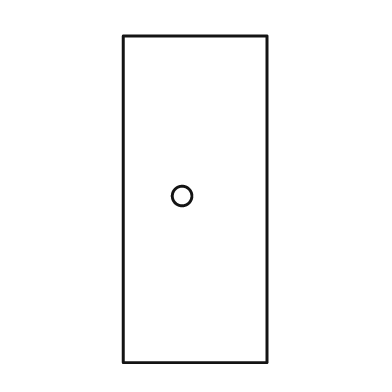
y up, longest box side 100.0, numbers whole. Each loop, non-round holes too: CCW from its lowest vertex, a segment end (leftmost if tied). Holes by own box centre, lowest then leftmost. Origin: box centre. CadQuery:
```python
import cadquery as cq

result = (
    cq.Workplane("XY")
    .moveTo(-22.0, -50.0)
    .lineTo(22.0, -50.0)
    .lineTo(22.0, 50.0)
    .lineTo(-22.0, 50.0)
    .close()
    .moveTo(-4.0, 1.0)
    .circle(3.0)
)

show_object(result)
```